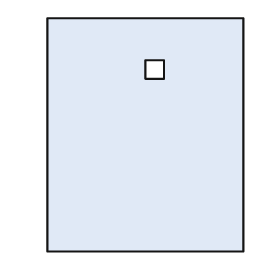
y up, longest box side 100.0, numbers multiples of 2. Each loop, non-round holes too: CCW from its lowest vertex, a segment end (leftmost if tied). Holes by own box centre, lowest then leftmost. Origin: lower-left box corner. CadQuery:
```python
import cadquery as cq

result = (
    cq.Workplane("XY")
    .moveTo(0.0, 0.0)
    .lineTo(84.0, 0.0)
    .lineTo(84.0, 100.0)
    .lineTo(0.0, 100.0)
    .close()
    .moveTo(42.0, 74.0)
    .lineTo(50.0, 74.0)
    .lineTo(50.0, 82.0)
    .lineTo(42.0, 82.0)
    .close()
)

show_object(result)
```